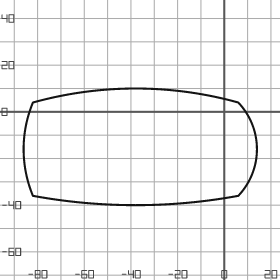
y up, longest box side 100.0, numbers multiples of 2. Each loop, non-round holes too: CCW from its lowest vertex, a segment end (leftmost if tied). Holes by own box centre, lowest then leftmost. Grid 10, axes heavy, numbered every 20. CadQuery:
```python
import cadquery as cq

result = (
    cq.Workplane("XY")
    .moveTo(-82.0, -36.0)
    .threePointArc((-38.0, -40.0), (6.0, -36.0))
    .threePointArc((14.0, -16.0), (6.0, 4.0))
    .threePointArc((-38.0, 10.0), (-82.0, 4.0))
    .threePointArc((-86.0, -16.0), (-82.0, -36.0))
    .close()
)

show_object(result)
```